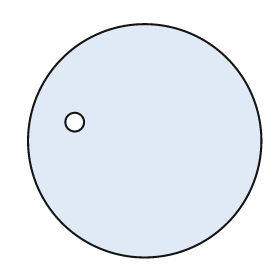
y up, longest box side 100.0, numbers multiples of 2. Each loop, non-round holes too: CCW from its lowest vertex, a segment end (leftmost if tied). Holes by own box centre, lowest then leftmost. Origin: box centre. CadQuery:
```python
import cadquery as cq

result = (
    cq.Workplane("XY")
    .moveTo(0.0, 0.0)
    .circle(50.0)
    .moveTo(-30.0, 8.0)
    .circle(4.0)
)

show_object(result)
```